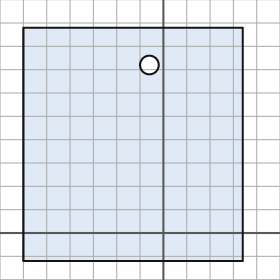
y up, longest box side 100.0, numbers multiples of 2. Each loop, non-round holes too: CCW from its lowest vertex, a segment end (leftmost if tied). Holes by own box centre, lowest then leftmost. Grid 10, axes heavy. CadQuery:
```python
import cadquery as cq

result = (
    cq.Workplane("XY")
    .moveTo(-60.0, -12.0)
    .lineTo(34.0, -12.0)
    .lineTo(34.0, 88.0)
    .lineTo(-60.0, 88.0)
    .close()
    .moveTo(-6.0, 72.0)
    .circle(4.0)
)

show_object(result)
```